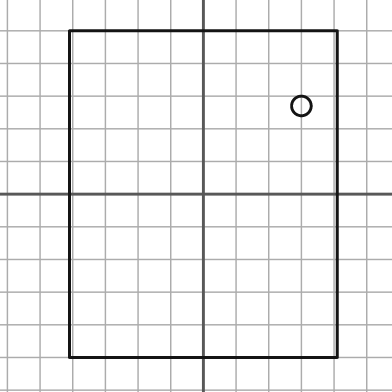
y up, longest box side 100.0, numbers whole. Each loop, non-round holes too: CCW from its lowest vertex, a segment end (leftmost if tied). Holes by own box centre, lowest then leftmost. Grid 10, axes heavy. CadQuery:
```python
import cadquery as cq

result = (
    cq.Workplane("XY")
    .moveTo(-41.0, -50.0)
    .lineTo(41.0, -50.0)
    .lineTo(41.0, 50.0)
    .lineTo(-41.0, 50.0)
    .close()
    .moveTo(30.0, 27.0)
    .circle(3.0)
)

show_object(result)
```